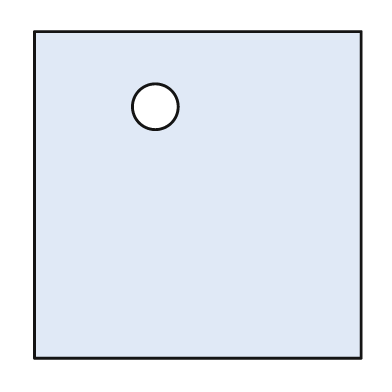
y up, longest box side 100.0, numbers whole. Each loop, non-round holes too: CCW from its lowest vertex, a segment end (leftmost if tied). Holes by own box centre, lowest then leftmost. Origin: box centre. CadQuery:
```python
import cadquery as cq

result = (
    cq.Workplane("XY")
    .moveTo(-50.0, -50.0)
    .lineTo(50.0, -50.0)
    .lineTo(50.0, 50.0)
    .lineTo(-50.0, 50.0)
    .close()
    .moveTo(-13.0, 27.0)
    .circle(7.0)
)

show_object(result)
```